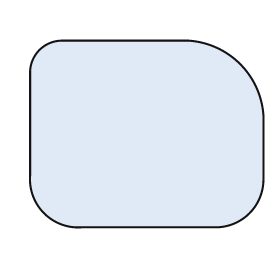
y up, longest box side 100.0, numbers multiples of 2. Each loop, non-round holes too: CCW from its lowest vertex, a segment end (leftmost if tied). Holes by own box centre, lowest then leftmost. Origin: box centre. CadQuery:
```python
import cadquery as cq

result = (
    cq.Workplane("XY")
    .moveTo(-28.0, -40.0)
    .lineTo(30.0, -40.0)
    .threePointArc((44.0, -34.0), (50.0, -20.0))
    .lineTo(50.0, 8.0)
    .threePointArc((40.0, 30.0), (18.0, 40.0))
    .lineTo(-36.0, 40.0)
    .threePointArc((-46.0, 36.0), (-50.0, 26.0))
    .lineTo(-50.0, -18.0)
    .threePointArc((-44.0, -34.0), (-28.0, -40.0))
    .close()
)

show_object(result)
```